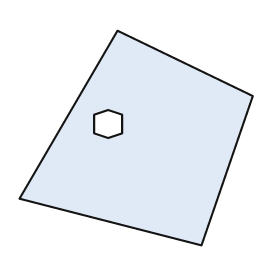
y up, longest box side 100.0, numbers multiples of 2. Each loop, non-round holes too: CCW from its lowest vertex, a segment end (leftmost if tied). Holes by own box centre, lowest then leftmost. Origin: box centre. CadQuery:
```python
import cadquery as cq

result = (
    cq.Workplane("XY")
    .moveTo(28.0, -46.0)
    .lineTo(50.0, 18.0)
    .lineTo(-8.0, 46.0)
    .lineTo(-50.0, -26.0)
    .close()
    .moveTo(-12.0, 0.0)
    .lineTo(-6.0, 2.0)
    .lineTo(-6.0, 10.0)
    .lineTo(-12.0, 12.0)
    .lineTo(-18.0, 10.0)
    .lineTo(-18.0, 2.0)
    .close()
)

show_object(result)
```